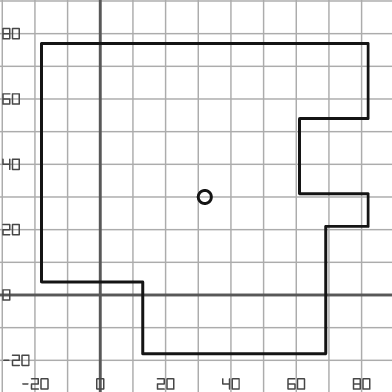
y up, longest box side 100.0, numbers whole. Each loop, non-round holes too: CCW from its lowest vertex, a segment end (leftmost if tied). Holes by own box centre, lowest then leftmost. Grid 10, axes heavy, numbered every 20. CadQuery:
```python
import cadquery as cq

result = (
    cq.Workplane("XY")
    .moveTo(13.0, -18.0)
    .lineTo(69.0, -18.0)
    .lineTo(69.0, 21.0)
    .lineTo(82.0, 21.0)
    .lineTo(82.0, 31.0)
    .lineTo(61.0, 31.0)
    .lineTo(61.0, 54.0)
    .lineTo(82.0, 54.0)
    .lineTo(82.0, 77.0)
    .lineTo(-18.0, 77.0)
    .lineTo(-18.0, 4.0)
    .lineTo(13.0, 4.0)
    .close()
    .moveTo(32.0, 30.0)
    .circle(2.0)
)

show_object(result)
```